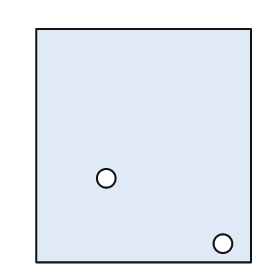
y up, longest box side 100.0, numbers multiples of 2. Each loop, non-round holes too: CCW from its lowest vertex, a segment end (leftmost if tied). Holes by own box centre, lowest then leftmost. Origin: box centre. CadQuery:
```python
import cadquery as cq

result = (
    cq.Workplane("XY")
    .moveTo(-46.0, -50.0)
    .lineTo(46.0, -50.0)
    .lineTo(46.0, 50.0)
    .lineTo(-46.0, 50.0)
    .close()
    .moveTo(34.0, -42.0)
    .circle(4.0)
    .moveTo(-16.0, -14.0)
    .circle(4.0)
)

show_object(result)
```